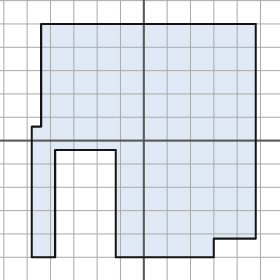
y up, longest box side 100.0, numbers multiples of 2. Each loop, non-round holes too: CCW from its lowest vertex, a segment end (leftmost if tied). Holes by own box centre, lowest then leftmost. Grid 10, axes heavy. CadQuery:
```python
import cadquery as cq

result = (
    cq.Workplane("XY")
    .moveTo(-48.0, -50.0)
    .lineTo(-38.0, -50.0)
    .lineTo(-38.0, -4.0)
    .lineTo(-12.0, -4.0)
    .lineTo(-12.0, -50.0)
    .lineTo(30.0, -50.0)
    .lineTo(30.0, -42.0)
    .lineTo(48.0, -42.0)
    .lineTo(48.0, 50.0)
    .lineTo(-44.0, 50.0)
    .lineTo(-44.0, 6.0)
    .lineTo(-48.0, 6.0)
    .close()
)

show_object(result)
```